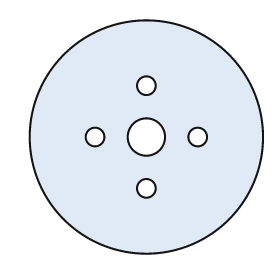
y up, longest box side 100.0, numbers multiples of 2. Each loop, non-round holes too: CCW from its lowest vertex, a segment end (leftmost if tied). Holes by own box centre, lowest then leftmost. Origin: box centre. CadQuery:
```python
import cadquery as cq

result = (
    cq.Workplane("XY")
    .moveTo(0.0, 0.0)
    .circle(50.0)
    .moveTo(0.0, -22.0)
    .circle(4.0)
    .moveTo(-22.0, 0.0)
    .circle(4.0)
    .moveTo(0.0, 0.0)
    .circle(8.0)
    .moveTo(22.0, 0.0)
    .circle(4.0)
    .moveTo(0.0, 22.0)
    .circle(4.0)
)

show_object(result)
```